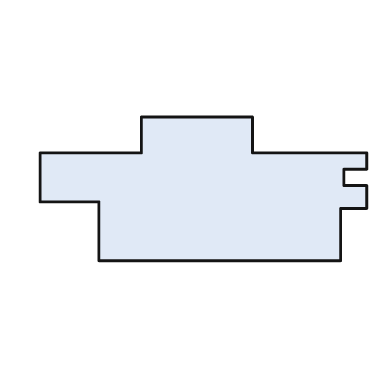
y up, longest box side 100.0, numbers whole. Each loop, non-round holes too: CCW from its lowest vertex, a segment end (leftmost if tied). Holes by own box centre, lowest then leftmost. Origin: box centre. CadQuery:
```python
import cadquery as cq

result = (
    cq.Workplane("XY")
    .moveTo(-32.0, -22.0)
    .lineTo(42.0, -22.0)
    .lineTo(42.0, -6.0)
    .lineTo(50.0, -6.0)
    .lineTo(50.0, 1.0)
    .lineTo(43.0, 1.0)
    .lineTo(43.0, 6.0)
    .lineTo(50.0, 6.0)
    .lineTo(50.0, 11.0)
    .lineTo(15.0, 11.0)
    .lineTo(15.0, 22.0)
    .lineTo(-19.0, 22.0)
    .lineTo(-19.0, 11.0)
    .lineTo(-50.0, 11.0)
    .lineTo(-50.0, -4.0)
    .lineTo(-32.0, -4.0)
    .close()
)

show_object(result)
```